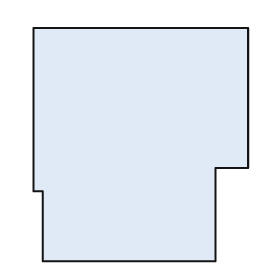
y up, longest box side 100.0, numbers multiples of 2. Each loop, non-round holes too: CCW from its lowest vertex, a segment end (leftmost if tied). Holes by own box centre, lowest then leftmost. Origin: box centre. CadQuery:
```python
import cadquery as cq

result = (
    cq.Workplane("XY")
    .moveTo(-42.0, -50.0)
    .lineTo(32.0, -50.0)
    .lineTo(32.0, -10.0)
    .lineTo(46.0, -10.0)
    .lineTo(46.0, 50.0)
    .lineTo(-46.0, 50.0)
    .lineTo(-46.0, -20.0)
    .lineTo(-42.0, -20.0)
    .close()
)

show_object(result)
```